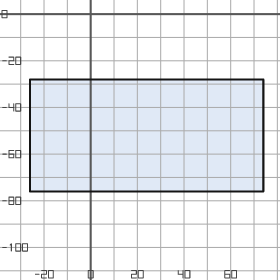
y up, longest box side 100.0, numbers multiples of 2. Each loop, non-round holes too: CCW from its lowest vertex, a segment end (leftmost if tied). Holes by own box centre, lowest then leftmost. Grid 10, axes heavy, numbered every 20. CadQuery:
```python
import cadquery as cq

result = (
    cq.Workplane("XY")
    .moveTo(-26.0, -76.0)
    .lineTo(74.0, -76.0)
    .lineTo(74.0, -28.0)
    .lineTo(-26.0, -28.0)
    .close()
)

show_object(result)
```